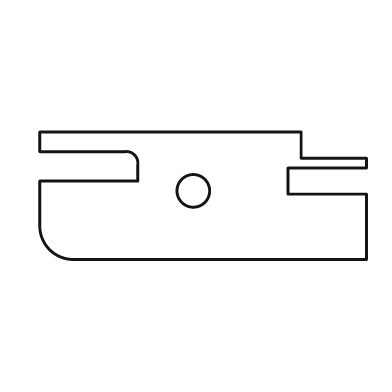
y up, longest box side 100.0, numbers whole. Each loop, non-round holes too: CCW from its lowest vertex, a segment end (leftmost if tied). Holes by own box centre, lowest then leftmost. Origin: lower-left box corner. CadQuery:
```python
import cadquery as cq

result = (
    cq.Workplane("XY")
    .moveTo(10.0, 0.0)
    .lineTo(100.0, 0.0)
    .lineTo(100.0, 20.0)
    .lineTo(76.0, 20.0)
    .lineTo(76.0, 28.0)
    .lineTo(100.0, 28.0)
    .lineTo(100.0, 31.0)
    .lineTo(80.0, 31.0)
    .lineTo(80.0, 39.0)
    .lineTo(0.0, 39.0)
    .lineTo(0.0, 33.0)
    .lineTo(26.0, 33.0)
    .threePointArc((29.0, 32.0), (30.0, 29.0))
    .lineTo(30.0, 24.0)
    .lineTo(0.0, 24.0)
    .lineTo(0.0, 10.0)
    .threePointArc((3.0, 3.0), (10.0, 0.0))
    .close()
    .moveTo(47.0, 21.0)
    .circle(5.0)
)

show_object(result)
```